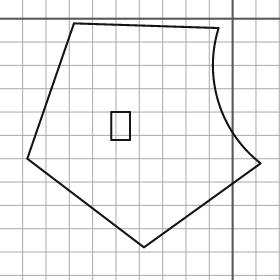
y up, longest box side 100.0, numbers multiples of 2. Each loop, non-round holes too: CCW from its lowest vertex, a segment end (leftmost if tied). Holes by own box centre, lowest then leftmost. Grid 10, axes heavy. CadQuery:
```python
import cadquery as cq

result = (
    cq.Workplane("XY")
    .moveTo(-38.0, -98.0)
    .lineTo(12.0, -62.0)
    .threePointArc((-6.0, -36.0), (-6.0, -4.0))
    .lineTo(-68.0, -2.0)
    .lineTo(-88.0, -60.0)
    .close()
    .moveTo(-52.0, -52.0)
    .lineTo(-44.0, -52.0)
    .lineTo(-44.0, -40.0)
    .lineTo(-52.0, -40.0)
    .close()
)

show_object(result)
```